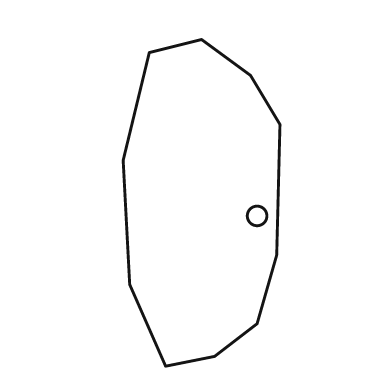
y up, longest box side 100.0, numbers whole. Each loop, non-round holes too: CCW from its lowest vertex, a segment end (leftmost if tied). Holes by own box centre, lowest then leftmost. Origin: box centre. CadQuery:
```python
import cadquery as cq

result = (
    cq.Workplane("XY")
    .moveTo(-11.0, -50.0)
    .lineTo(4.0, -47.0)
    .lineTo(17.0, -37.0)
    .lineTo(23.0, -16.0)
    .lineTo(24.0, 24.0)
    .lineTo(15.0, 39.0)
    .lineTo(0.0, 50.0)
    .lineTo(-16.0, 46.0)
    .lineTo(-24.0, 13.0)
    .lineTo(-22.0, -25.0)
    .close()
    .moveTo(17.0, -4.0)
    .circle(3.0)
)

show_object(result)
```